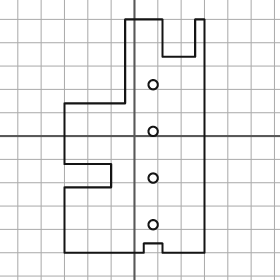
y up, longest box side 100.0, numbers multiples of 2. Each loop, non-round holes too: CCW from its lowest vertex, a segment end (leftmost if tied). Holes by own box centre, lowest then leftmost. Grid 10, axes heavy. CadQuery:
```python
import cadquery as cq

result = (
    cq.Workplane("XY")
    .moveTo(-30.0, -50.0)
    .lineTo(4.0, -50.0)
    .lineTo(4.0, -46.0)
    .lineTo(12.0, -46.0)
    .lineTo(12.0, -50.0)
    .lineTo(30.0, -50.0)
    .lineTo(30.0, 50.0)
    .lineTo(26.0, 50.0)
    .lineTo(26.0, 34.0)
    .lineTo(12.0, 34.0)
    .lineTo(12.0, 50.0)
    .lineTo(-4.0, 50.0)
    .lineTo(-4.0, 14.0)
    .lineTo(-30.0, 14.0)
    .lineTo(-30.0, -12.0)
    .lineTo(-10.0, -12.0)
    .lineTo(-10.0, -22.0)
    .lineTo(-30.0, -22.0)
    .close()
    .moveTo(8.0, -38.0)
    .circle(2.0)
    .moveTo(8.0, -18.0)
    .circle(2.0)
    .moveTo(8.0, 2.0)
    .circle(2.0)
    .moveTo(8.0, 22.0)
    .circle(2.0)
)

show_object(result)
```